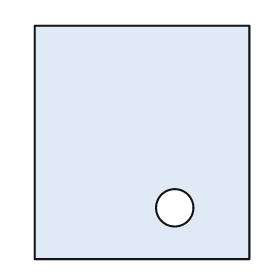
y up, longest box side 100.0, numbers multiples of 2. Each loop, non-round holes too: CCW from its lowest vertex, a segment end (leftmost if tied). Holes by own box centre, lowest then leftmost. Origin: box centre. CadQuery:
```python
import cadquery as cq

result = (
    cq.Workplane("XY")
    .moveTo(-46.0, -50.0)
    .lineTo(46.0, -50.0)
    .lineTo(46.0, 50.0)
    .lineTo(-46.0, 50.0)
    .close()
    .moveTo(14.0, -28.0)
    .circle(8.0)
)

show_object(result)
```